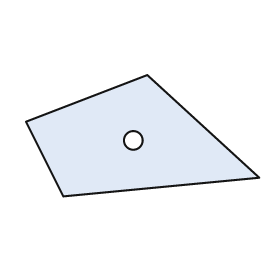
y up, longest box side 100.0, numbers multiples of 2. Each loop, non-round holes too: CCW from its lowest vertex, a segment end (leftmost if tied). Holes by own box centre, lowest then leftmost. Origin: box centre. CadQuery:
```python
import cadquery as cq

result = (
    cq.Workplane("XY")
    .moveTo(-34.0, -26.0)
    .lineTo(50.0, -18.0)
    .lineTo(2.0, 26.0)
    .lineTo(-50.0, 6.0)
    .close()
    .moveTo(-4.0, -2.0)
    .circle(4.0)
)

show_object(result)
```